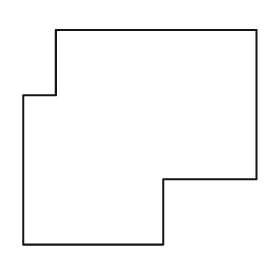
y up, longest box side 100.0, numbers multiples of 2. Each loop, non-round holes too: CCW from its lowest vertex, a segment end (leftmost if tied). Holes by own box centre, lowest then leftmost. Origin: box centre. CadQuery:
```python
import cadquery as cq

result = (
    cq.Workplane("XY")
    .moveTo(-50.0, -46.0)
    .lineTo(10.0, -46.0)
    .lineTo(10.0, -18.0)
    .lineTo(50.0, -18.0)
    .lineTo(50.0, 46.0)
    .lineTo(-36.0, 46.0)
    .lineTo(-36.0, 18.0)
    .lineTo(-50.0, 18.0)
    .close()
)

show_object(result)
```